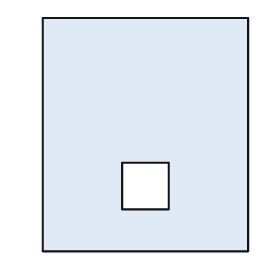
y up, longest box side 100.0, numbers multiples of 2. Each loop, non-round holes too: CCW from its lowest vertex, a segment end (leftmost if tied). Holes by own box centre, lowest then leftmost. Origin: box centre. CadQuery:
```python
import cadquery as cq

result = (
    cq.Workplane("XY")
    .moveTo(-44.0, -50.0)
    .lineTo(44.0, -50.0)
    .lineTo(44.0, 50.0)
    .lineTo(-44.0, 50.0)
    .close()
    .moveTo(-10.0, -32.0)
    .lineTo(10.0, -32.0)
    .lineTo(10.0, -12.0)
    .lineTo(-10.0, -12.0)
    .close()
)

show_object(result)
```